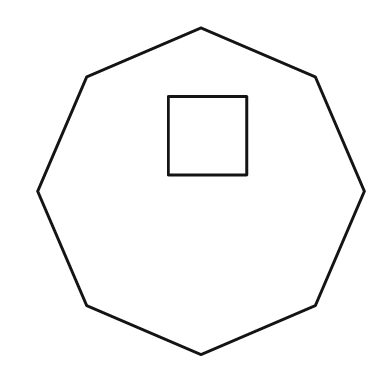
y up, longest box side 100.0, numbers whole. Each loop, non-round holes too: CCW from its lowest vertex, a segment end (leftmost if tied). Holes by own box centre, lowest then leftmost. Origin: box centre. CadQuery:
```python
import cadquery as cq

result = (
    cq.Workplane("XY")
    .moveTo(0.0, -50.0)
    .lineTo(35.0, -35.0)
    .lineTo(50.0, 0.0)
    .lineTo(35.0, 35.0)
    .lineTo(0.0, 50.0)
    .lineTo(-35.0, 35.0)
    .lineTo(-50.0, 0.0)
    .lineTo(-35.0, -35.0)
    .close()
    .moveTo(-10.0, 5.0)
    .lineTo(14.0, 5.0)
    .lineTo(14.0, 29.0)
    .lineTo(-10.0, 29.0)
    .close()
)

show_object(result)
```